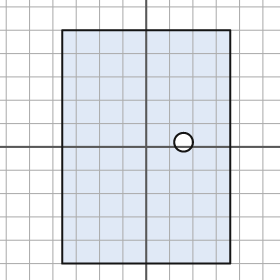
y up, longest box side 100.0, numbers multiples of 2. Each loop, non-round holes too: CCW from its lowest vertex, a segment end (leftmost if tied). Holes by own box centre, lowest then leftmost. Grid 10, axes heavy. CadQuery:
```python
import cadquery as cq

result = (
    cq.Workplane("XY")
    .moveTo(-36.0, -50.0)
    .lineTo(36.0, -50.0)
    .lineTo(36.0, 50.0)
    .lineTo(-36.0, 50.0)
    .close()
    .moveTo(16.0, 2.0)
    .circle(4.0)
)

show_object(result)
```